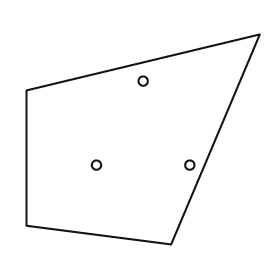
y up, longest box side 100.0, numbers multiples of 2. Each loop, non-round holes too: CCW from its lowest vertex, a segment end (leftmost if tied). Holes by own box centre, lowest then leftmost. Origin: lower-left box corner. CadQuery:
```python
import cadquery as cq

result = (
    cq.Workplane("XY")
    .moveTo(62.0, 0.0)
    .lineTo(100.0, 90.0)
    .lineTo(0.0, 66.0)
    .lineTo(0.0, 8.0)
    .close()
    .moveTo(30.0, 34.0)
    .circle(2.0)
    .moveTo(70.0, 34.0)
    .circle(2.0)
    .moveTo(50.0, 70.0)
    .circle(2.0)
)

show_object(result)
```